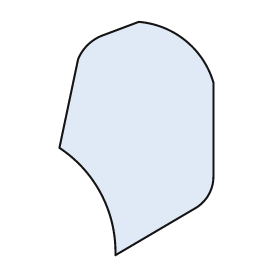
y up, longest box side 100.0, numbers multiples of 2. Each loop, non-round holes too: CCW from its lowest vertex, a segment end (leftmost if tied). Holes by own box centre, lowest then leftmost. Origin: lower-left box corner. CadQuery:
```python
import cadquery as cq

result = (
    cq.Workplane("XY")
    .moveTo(24.0, 0.0)
    .lineTo(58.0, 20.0)
    .threePointArc((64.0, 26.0), (66.0, 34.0))
    .lineTo(66.0, 74.0)
    .threePointArc((54.0, 92.0), (34.0, 100.0))
    .lineTo(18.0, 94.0)
    .threePointArc((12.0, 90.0), (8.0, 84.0))
    .lineTo(0.0, 46.0)
    .threePointArc((18.0, 26.0), (24.0, 0.0))
    .close()
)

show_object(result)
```